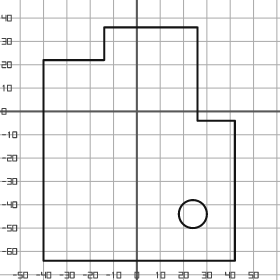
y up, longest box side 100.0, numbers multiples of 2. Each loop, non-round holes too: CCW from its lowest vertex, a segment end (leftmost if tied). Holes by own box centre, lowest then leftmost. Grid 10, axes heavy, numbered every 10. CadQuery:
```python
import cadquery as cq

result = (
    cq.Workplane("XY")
    .moveTo(-40.0, -64.0)
    .lineTo(42.0, -64.0)
    .lineTo(42.0, -4.0)
    .lineTo(26.0, -4.0)
    .lineTo(26.0, 36.0)
    .lineTo(-14.0, 36.0)
    .lineTo(-14.0, 22.0)
    .lineTo(-40.0, 22.0)
    .close()
    .moveTo(24.0, -44.0)
    .circle(6.0)
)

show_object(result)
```